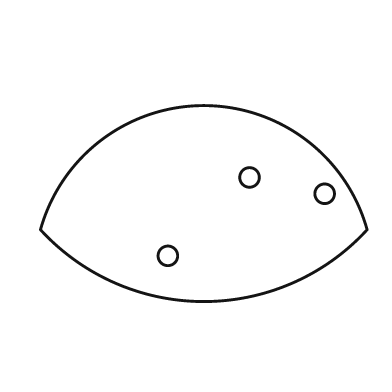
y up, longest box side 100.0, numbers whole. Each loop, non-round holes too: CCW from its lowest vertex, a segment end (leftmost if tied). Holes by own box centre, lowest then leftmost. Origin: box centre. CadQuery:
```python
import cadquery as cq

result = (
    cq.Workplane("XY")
    .moveTo(-50.0, -8.0)
    .threePointArc((0.0, -30.0), (50.0, -8.0))
    .threePointArc((0.0, 30.0), (-50.0, -8.0))
    .close()
    .moveTo(-11.0, -16.0)
    .circle(3.0)
    .moveTo(37.0, 3.0)
    .circle(3.0)
    .moveTo(14.0, 8.0)
    .circle(3.0)
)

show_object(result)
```